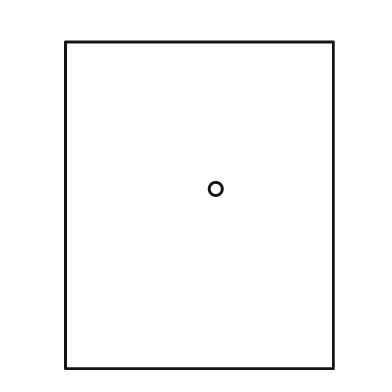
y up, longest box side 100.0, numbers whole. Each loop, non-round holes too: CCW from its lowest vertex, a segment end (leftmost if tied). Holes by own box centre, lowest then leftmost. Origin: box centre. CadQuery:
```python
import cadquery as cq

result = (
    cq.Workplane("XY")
    .moveTo(-41.0, -50.0)
    .lineTo(41.0, -50.0)
    .lineTo(41.0, 50.0)
    .lineTo(-41.0, 50.0)
    .close()
    .moveTo(5.0, 5.0)
    .circle(2.0)
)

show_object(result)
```